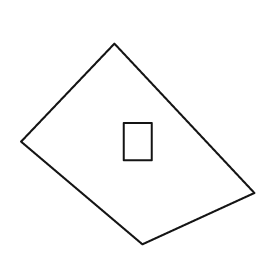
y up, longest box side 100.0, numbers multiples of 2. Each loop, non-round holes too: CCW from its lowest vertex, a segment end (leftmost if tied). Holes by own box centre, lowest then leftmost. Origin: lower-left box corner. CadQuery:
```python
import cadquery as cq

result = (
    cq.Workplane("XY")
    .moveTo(52.0, 0.0)
    .lineTo(100.0, 22.0)
    .lineTo(40.0, 86.0)
    .lineTo(0.0, 44.0)
    .close()
    .moveTo(44.0, 36.0)
    .lineTo(56.0, 36.0)
    .lineTo(56.0, 52.0)
    .lineTo(44.0, 52.0)
    .close()
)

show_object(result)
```